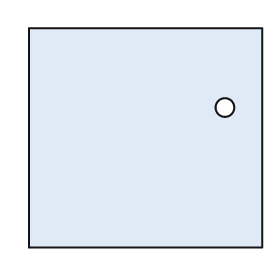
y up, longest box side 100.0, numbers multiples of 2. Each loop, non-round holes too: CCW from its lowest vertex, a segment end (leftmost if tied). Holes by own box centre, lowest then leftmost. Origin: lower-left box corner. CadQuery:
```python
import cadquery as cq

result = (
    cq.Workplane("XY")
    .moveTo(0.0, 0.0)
    .lineTo(100.0, 0.0)
    .lineTo(100.0, 94.0)
    .lineTo(0.0, 94.0)
    .close()
    .moveTo(84.0, 60.0)
    .circle(4.0)
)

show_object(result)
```